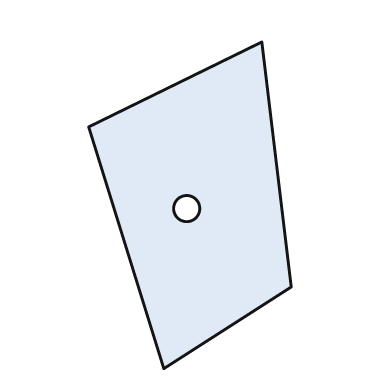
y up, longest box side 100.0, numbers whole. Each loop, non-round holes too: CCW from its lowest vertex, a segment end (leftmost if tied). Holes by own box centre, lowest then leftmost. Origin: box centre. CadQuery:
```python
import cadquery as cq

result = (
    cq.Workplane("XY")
    .moveTo(-8.0, -50.0)
    .lineTo(31.0, -25.0)
    .lineTo(22.0, 50.0)
    .lineTo(-31.0, 24.0)
    .close()
    .moveTo(-1.0, -1.0)
    .circle(4.0)
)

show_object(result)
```